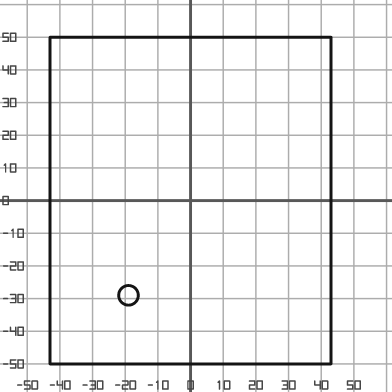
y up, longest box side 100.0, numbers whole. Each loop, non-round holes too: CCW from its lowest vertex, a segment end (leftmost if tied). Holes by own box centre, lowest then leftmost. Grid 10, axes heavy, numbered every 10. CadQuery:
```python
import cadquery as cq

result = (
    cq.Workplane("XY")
    .moveTo(-43.0, -50.0)
    .lineTo(43.0, -50.0)
    .lineTo(43.0, 50.0)
    .lineTo(-43.0, 50.0)
    .close()
    .moveTo(-19.0, -29.0)
    .circle(3.0)
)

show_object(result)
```